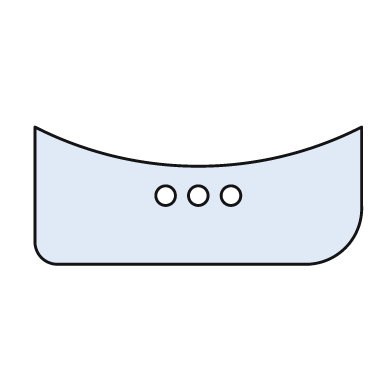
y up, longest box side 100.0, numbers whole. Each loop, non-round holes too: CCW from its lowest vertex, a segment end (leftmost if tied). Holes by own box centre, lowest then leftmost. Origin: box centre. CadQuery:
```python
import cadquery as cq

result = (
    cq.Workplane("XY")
    .moveTo(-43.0, -21.0)
    .lineTo(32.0, -21.0)
    .threePointArc((45.0, -16.0), (50.0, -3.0))
    .lineTo(50.0, 21.0)
    .threePointArc((0.0, 9.0), (-50.0, 21.0))
    .lineTo(-50.0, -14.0)
    .threePointArc((-48.0, -19.0), (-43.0, -21.0))
    .close()
    .moveTo(-10.0, 0.0)
    .circle(3.0)
    .moveTo(0.0, 0.0)
    .circle(3.0)
    .moveTo(10.0, 0.0)
    .circle(3.0)
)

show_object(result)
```